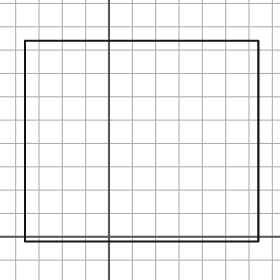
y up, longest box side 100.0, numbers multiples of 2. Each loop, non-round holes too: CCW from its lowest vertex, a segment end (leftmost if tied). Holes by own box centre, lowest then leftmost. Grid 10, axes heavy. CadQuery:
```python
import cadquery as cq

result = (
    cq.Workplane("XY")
    .moveTo(-36.0, -2.0)
    .lineTo(64.0, -2.0)
    .lineTo(64.0, 84.0)
    .lineTo(-36.0, 84.0)
    .close()
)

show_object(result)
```